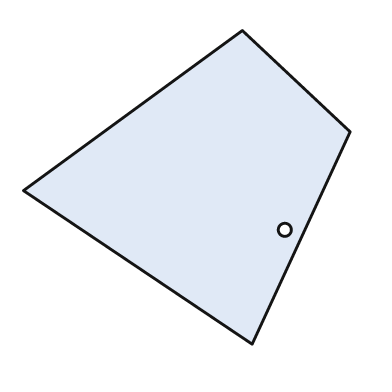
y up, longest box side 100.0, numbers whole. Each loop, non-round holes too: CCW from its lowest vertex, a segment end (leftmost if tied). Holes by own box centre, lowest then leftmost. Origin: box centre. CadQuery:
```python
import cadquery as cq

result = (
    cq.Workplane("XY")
    .moveTo(20.0, -48.0)
    .lineTo(50.0, 17.0)
    .lineTo(17.0, 48.0)
    .lineTo(-50.0, -1.0)
    .close()
    .moveTo(30.0, -13.0)
    .circle(2.0)
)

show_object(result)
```